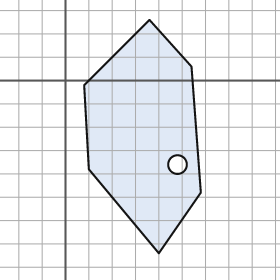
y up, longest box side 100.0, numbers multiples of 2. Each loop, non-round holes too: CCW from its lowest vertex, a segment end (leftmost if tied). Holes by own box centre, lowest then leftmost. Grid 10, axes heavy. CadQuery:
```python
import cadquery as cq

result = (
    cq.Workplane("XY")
    .moveTo(40.0, -74.0)
    .lineTo(58.0, -48.0)
    .lineTo(54.0, 6.0)
    .lineTo(36.0, 26.0)
    .lineTo(8.0, -2.0)
    .lineTo(10.0, -38.0)
    .close()
    .moveTo(48.0, -36.0)
    .circle(4.0)
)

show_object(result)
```